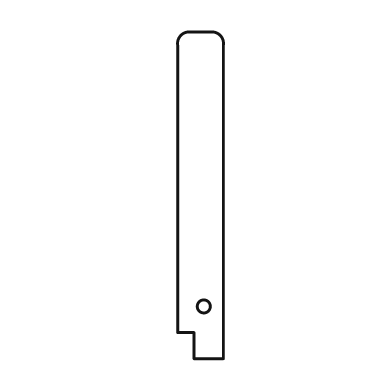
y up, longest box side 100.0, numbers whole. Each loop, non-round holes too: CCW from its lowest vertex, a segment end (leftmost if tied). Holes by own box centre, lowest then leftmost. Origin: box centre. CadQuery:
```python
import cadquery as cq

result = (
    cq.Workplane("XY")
    .moveTo(-2.0, -50.0)
    .lineTo(7.0, -50.0)
    .lineTo(7.0, 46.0)
    .threePointArc((6.0, 49.0), (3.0, 50.0))
    .lineTo(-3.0, 50.0)
    .threePointArc((-6.0, 49.0), (-7.0, 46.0))
    .lineTo(-7.0, -42.0)
    .lineTo(-2.0, -42.0)
    .close()
    .moveTo(1.0, -34.0)
    .circle(2.0)
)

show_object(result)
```